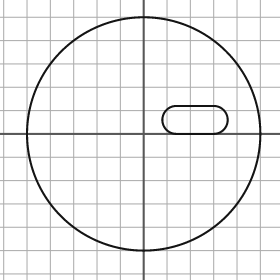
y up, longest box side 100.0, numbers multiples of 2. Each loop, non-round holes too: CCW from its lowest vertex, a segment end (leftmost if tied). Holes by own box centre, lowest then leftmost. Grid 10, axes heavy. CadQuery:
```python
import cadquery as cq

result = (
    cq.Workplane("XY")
    .moveTo(0.0, 0.0)
    .circle(50.0)
    .moveTo(14.0, 0.0)
    .lineTo(30.0, 0.0)
    .threePointArc((36.0, 6.0), (30.0, 12.0))
    .lineTo(14.0, 12.0)
    .threePointArc((8.0, 6.0), (14.0, 0.0))
    .close()
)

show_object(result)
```